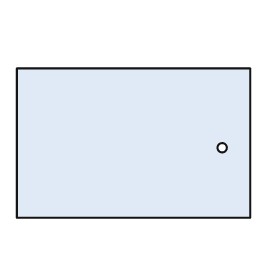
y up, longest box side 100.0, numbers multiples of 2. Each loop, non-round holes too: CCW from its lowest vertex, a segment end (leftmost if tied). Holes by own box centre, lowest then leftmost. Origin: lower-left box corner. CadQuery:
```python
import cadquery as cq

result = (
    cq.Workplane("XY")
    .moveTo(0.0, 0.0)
    .lineTo(100.0, 0.0)
    .lineTo(100.0, 64.0)
    .lineTo(0.0, 64.0)
    .close()
    .moveTo(88.0, 30.0)
    .circle(2.0)
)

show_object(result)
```